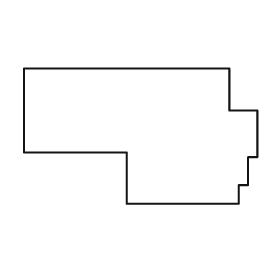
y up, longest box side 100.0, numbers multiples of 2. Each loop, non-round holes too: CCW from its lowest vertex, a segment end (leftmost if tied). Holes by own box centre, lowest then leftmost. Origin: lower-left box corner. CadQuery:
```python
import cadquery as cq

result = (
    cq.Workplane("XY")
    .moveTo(44.0, 0.0)
    .lineTo(92.0, 0.0)
    .lineTo(92.0, 8.0)
    .lineTo(96.0, 8.0)
    .lineTo(96.0, 20.0)
    .lineTo(100.0, 20.0)
    .lineTo(100.0, 40.0)
    .lineTo(88.0, 40.0)
    .lineTo(88.0, 58.0)
    .lineTo(0.0, 58.0)
    .lineTo(0.0, 22.0)
    .lineTo(44.0, 22.0)
    .close()
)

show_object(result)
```